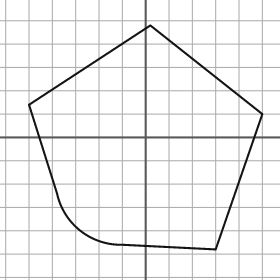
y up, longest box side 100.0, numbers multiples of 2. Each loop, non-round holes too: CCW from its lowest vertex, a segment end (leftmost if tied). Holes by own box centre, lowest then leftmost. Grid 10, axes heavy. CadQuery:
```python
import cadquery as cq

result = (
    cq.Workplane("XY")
    .moveTo(30.0, -48.0)
    .lineTo(50.0, 10.0)
    .lineTo(2.0, 48.0)
    .lineTo(-50.0, 14.0)
    .lineTo(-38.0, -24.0)
    .threePointArc((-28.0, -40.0), (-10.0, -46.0))
    .close()
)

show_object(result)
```